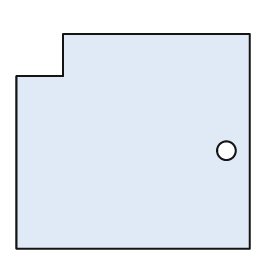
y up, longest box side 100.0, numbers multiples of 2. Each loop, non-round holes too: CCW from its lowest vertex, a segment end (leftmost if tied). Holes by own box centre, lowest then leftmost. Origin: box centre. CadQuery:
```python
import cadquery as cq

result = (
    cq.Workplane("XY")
    .moveTo(-50.0, -46.0)
    .lineTo(50.0, -46.0)
    .lineTo(50.0, 46.0)
    .lineTo(-30.0, 46.0)
    .lineTo(-30.0, 28.0)
    .lineTo(-50.0, 28.0)
    .close()
    .moveTo(40.0, -4.0)
    .circle(4.0)
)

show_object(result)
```